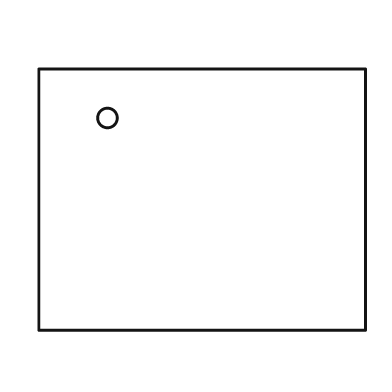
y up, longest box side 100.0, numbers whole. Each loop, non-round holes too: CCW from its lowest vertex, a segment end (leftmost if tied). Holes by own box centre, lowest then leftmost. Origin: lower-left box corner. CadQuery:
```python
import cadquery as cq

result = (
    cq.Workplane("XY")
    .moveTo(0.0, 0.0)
    .lineTo(100.0, 0.0)
    .lineTo(100.0, 80.0)
    .lineTo(0.0, 80.0)
    .close()
    .moveTo(21.0, 65.0)
    .circle(3.0)
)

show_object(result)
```